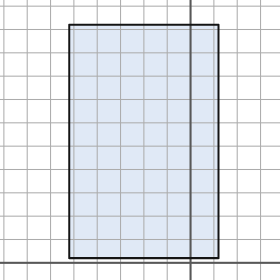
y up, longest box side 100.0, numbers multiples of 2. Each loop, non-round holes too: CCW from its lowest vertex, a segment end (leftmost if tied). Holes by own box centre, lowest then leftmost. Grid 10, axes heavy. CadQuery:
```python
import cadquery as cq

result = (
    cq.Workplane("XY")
    .moveTo(-52.0, 2.0)
    .lineTo(12.0, 2.0)
    .lineTo(12.0, 102.0)
    .lineTo(-52.0, 102.0)
    .close()
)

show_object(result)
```